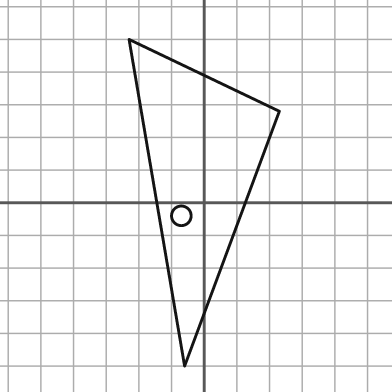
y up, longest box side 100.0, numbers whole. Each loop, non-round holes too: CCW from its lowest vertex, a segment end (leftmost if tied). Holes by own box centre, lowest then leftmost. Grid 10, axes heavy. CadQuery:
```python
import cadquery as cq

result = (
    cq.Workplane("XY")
    .moveTo(-6.0, -50.0)
    .lineTo(23.0, 28.0)
    .lineTo(-23.0, 50.0)
    .close()
    .moveTo(-7.0, -4.0)
    .circle(3.0)
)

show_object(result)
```